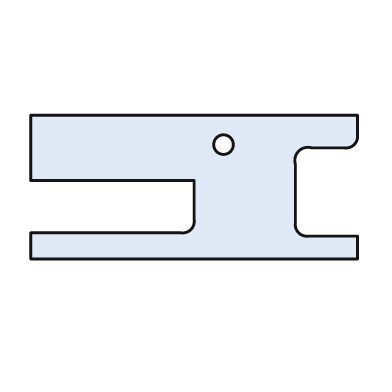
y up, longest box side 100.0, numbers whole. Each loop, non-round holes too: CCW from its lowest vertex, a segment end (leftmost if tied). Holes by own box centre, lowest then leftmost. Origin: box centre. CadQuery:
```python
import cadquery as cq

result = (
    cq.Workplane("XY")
    .moveTo(-50.0, -22.0)
    .lineTo(50.0, -22.0)
    .lineTo(50.0, -15.0)
    .lineTo(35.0, -15.0)
    .threePointArc((32.0, -14.0), (31.0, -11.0))
    .lineTo(31.0, 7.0)
    .threePointArc((32.0, 11.0), (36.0, 12.0))
    .lineTo(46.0, 12.0)
    .threePointArc((49.0, 13.0), (50.0, 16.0))
    .lineTo(50.0, 22.0)
    .lineTo(-50.0, 22.0)
    .lineTo(-50.0, 2.0)
    .lineTo(0.0, 2.0)
    .lineTo(0.0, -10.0)
    .threePointArc((-1.0, -13.0), (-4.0, -14.0))
    .lineTo(-50.0, -14.0)
    .close()
    .moveTo(9.0, 13.0)
    .circle(3.0)
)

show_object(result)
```